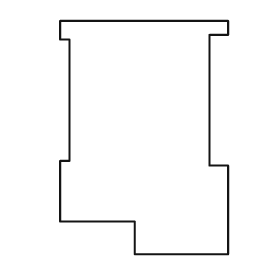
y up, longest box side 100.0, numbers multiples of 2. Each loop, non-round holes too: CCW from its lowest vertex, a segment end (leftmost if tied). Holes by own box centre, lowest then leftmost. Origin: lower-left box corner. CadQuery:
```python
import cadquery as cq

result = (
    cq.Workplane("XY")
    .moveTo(32.0, 0.0)
    .lineTo(72.0, 0.0)
    .lineTo(72.0, 38.0)
    .lineTo(64.0, 38.0)
    .lineTo(64.0, 94.0)
    .lineTo(72.0, 94.0)
    .lineTo(72.0, 100.0)
    .lineTo(0.0, 100.0)
    .lineTo(0.0, 92.0)
    .lineTo(4.0, 92.0)
    .lineTo(4.0, 40.0)
    .lineTo(0.0, 40.0)
    .lineTo(0.0, 14.0)
    .lineTo(32.0, 14.0)
    .close()
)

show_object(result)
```